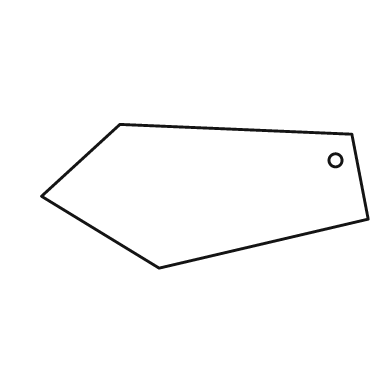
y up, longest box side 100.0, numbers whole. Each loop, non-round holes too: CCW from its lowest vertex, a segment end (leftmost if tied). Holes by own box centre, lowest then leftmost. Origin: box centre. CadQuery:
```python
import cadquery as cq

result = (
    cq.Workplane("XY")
    .moveTo(-14.0, -22.0)
    .lineTo(50.0, -7.0)
    .lineTo(45.0, 19.0)
    .lineTo(-26.0, 22.0)
    .lineTo(-50.0, 0.0)
    .close()
    .moveTo(40.0, 11.0)
    .circle(2.0)
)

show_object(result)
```